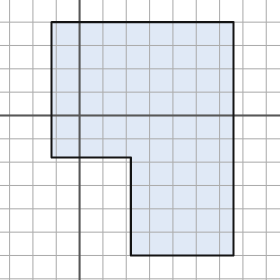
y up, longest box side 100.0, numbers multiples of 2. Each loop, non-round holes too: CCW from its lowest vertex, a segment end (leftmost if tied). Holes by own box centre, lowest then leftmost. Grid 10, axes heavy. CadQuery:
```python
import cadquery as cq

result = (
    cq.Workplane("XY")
    .moveTo(22.0, -60.0)
    .lineTo(66.0, -60.0)
    .lineTo(66.0, 40.0)
    .lineTo(-12.0, 40.0)
    .lineTo(-12.0, -18.0)
    .lineTo(22.0, -18.0)
    .close()
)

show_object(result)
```